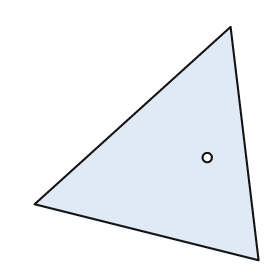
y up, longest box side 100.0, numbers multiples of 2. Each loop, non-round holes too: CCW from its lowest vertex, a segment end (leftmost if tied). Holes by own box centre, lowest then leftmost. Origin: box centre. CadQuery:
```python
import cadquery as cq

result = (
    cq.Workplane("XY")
    .moveTo(48.0, -50.0)
    .lineTo(36.0, 50.0)
    .lineTo(-48.0, -26.0)
    .close()
    .moveTo(26.0, -6.0)
    .circle(2.0)
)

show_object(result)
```